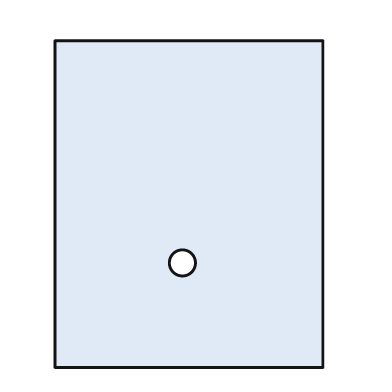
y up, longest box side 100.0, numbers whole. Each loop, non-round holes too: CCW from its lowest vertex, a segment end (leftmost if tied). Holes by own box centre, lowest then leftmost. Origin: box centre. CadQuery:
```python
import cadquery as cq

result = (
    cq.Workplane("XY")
    .moveTo(-41.0, -50.0)
    .lineTo(41.0, -50.0)
    .lineTo(41.0, 50.0)
    .lineTo(-41.0, 50.0)
    .close()
    .moveTo(-2.0, -18.0)
    .circle(4.0)
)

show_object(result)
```